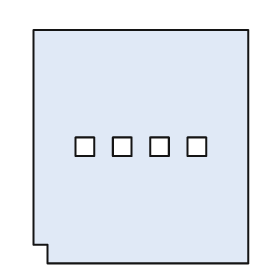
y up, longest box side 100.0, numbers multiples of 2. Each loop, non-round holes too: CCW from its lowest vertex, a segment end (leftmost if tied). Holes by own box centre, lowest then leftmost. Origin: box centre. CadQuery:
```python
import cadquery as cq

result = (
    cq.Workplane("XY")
    .moveTo(-40.0, -50.0)
    .lineTo(46.0, -50.0)
    .lineTo(46.0, 50.0)
    .lineTo(-46.0, 50.0)
    .lineTo(-46.0, -42.0)
    .lineTo(-40.0, -42.0)
    .close()
    .moveTo(-28.0, -4.0)
    .lineTo(-20.0, -4.0)
    .lineTo(-20.0, 4.0)
    .lineTo(-28.0, 4.0)
    .close()
    .moveTo(-12.0, -4.0)
    .lineTo(-4.0, -4.0)
    .lineTo(-4.0, 4.0)
    .lineTo(-12.0, 4.0)
    .close()
    .moveTo(4.0, -4.0)
    .lineTo(12.0, -4.0)
    .lineTo(12.0, 4.0)
    .lineTo(4.0, 4.0)
    .close()
    .moveTo(20.0, -4.0)
    .lineTo(28.0, -4.0)
    .lineTo(28.0, 4.0)
    .lineTo(20.0, 4.0)
    .close()
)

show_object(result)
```